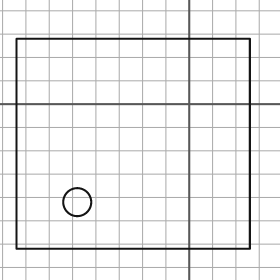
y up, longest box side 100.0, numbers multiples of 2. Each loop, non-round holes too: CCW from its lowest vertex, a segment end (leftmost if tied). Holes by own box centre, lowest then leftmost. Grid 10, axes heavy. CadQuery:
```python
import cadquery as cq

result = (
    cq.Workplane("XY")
    .moveTo(-74.0, -62.0)
    .lineTo(26.0, -62.0)
    .lineTo(26.0, 28.0)
    .lineTo(-74.0, 28.0)
    .close()
    .moveTo(-48.0, -42.0)
    .circle(6.0)
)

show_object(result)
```